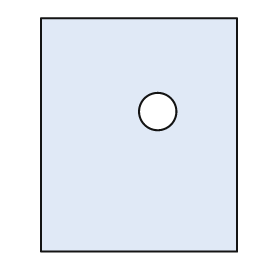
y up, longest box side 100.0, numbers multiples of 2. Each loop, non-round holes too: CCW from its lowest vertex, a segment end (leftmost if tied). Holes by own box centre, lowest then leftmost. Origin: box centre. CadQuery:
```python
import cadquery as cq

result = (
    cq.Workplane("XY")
    .moveTo(-42.0, -50.0)
    .lineTo(42.0, -50.0)
    .lineTo(42.0, 50.0)
    .lineTo(-42.0, 50.0)
    .close()
    .moveTo(8.0, 10.0)
    .circle(8.0)
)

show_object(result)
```